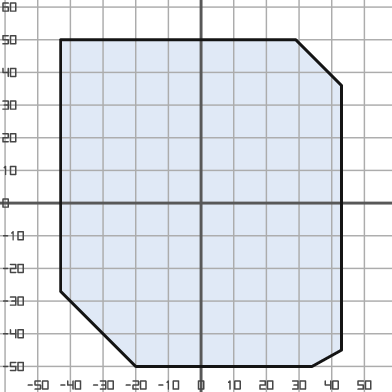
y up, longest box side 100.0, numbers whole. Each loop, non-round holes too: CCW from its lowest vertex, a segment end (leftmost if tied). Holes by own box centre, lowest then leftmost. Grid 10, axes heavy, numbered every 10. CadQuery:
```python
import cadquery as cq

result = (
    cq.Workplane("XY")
    .moveTo(-20.0, -50.0)
    .lineTo(34.0, -50.0)
    .lineTo(43.0, -45.0)
    .lineTo(43.0, 36.0)
    .lineTo(29.0, 50.0)
    .lineTo(-43.0, 50.0)
    .lineTo(-43.0, -27.0)
    .close()
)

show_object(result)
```